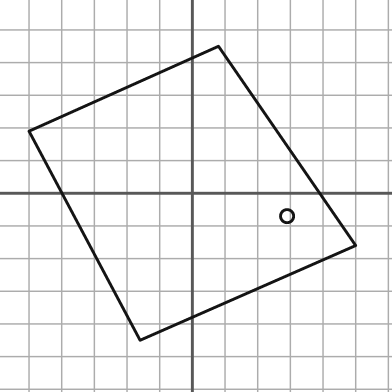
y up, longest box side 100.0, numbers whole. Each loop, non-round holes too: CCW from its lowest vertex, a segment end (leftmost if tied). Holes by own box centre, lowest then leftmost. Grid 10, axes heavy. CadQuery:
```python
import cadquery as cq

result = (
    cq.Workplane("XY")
    .moveTo(-16.0, -45.0)
    .lineTo(50.0, -16.0)
    .lineTo(8.0, 45.0)
    .lineTo(-50.0, 19.0)
    .close()
    .moveTo(29.0, -7.0)
    .circle(2.0)
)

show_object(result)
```